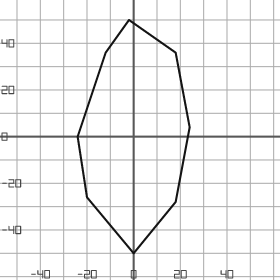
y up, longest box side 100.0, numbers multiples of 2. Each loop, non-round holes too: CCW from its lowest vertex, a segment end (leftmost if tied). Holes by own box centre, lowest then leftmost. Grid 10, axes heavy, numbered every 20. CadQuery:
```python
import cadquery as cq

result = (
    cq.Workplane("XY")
    .moveTo(0.0, -50.0)
    .lineTo(18.0, -28.0)
    .lineTo(24.0, 4.0)
    .lineTo(18.0, 36.0)
    .lineTo(-2.0, 50.0)
    .lineTo(-12.0, 36.0)
    .lineTo(-24.0, 0.0)
    .lineTo(-20.0, -26.0)
    .close()
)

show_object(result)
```